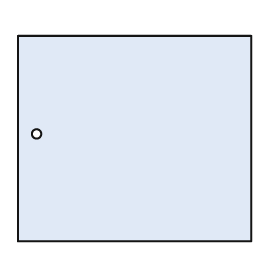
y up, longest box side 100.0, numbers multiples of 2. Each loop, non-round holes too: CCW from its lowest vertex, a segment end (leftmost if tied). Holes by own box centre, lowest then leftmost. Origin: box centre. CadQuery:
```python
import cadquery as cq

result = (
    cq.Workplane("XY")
    .moveTo(-50.0, -44.0)
    .lineTo(50.0, -44.0)
    .lineTo(50.0, 44.0)
    .lineTo(-50.0, 44.0)
    .close()
    .moveTo(-42.0, 2.0)
    .circle(2.0)
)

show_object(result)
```